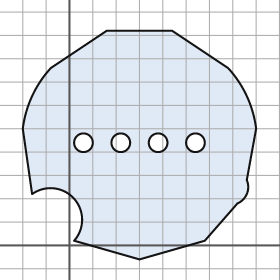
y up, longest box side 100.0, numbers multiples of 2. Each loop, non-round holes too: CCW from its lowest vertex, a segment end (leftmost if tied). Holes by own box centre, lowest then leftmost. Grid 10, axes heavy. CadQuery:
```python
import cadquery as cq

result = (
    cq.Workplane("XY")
    .moveTo(30.0, -6.0)
    .lineTo(58.0, 2.0)
    .lineTo(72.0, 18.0)
    .threePointArc((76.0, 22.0), (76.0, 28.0))
    .lineTo(80.0, 50.0)
    .threePointArc((76.0, 64.0), (68.0, 76.0))
    .lineTo(44.0, 92.0)
    .lineTo(16.0, 92.0)
    .lineTo(-8.0, 76.0)
    .threePointArc((-16.0, 64.0), (-20.0, 50.0))
    .lineTo(-16.0, 22.0)
    .threePointArc((2.0, 20.0), (2.0, 2.0))
    .close()
    .moveTo(6.0, 44.0)
    .circle(4.0)
    .moveTo(22.0, 44.0)
    .circle(4.0)
    .moveTo(38.0, 44.0)
    .circle(4.0)
    .moveTo(54.0, 44.0)
    .circle(4.0)
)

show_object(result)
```